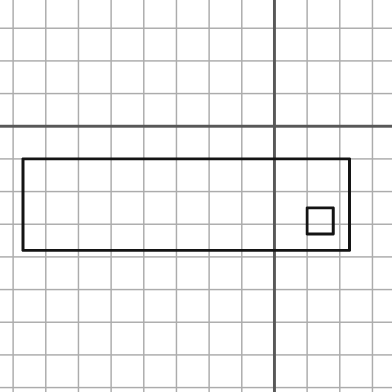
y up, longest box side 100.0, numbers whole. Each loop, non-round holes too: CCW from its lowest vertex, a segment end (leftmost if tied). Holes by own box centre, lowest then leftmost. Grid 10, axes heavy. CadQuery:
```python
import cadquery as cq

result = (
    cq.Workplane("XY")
    .moveTo(-77.0, -38.0)
    .lineTo(23.0, -38.0)
    .lineTo(23.0, -10.0)
    .lineTo(-77.0, -10.0)
    .close()
    .moveTo(10.0, -33.0)
    .lineTo(18.0, -33.0)
    .lineTo(18.0, -25.0)
    .lineTo(10.0, -25.0)
    .close()
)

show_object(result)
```